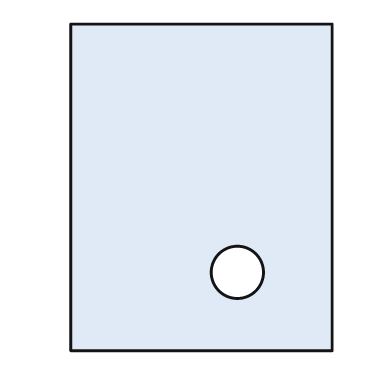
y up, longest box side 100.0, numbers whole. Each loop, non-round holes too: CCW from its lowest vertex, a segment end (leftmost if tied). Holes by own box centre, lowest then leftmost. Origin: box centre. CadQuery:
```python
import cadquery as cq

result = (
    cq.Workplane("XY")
    .moveTo(-40.0, -50.0)
    .lineTo(40.0, -50.0)
    .lineTo(40.0, 50.0)
    .lineTo(-40.0, 50.0)
    .close()
    .moveTo(11.0, -26.0)
    .circle(8.0)
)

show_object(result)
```